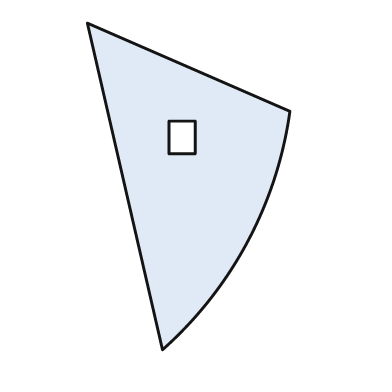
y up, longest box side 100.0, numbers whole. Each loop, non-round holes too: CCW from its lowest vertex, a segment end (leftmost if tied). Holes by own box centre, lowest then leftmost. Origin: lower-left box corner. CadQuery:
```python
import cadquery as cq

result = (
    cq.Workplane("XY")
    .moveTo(23.0, 0.0)
    .threePointArc((49.0, 33.0), (62.0, 73.0))
    .lineTo(0.0, 100.0)
    .close()
    .moveTo(25.0, 60.0)
    .lineTo(33.0, 60.0)
    .lineTo(33.0, 70.0)
    .lineTo(25.0, 70.0)
    .close()
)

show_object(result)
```